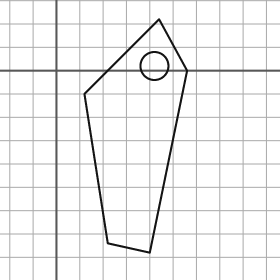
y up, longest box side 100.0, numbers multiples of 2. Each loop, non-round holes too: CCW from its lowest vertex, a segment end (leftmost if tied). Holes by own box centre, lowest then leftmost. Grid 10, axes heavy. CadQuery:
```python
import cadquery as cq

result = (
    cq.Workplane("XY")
    .moveTo(40.0, -78.0)
    .lineTo(56.0, 0.0)
    .lineTo(44.0, 22.0)
    .lineTo(12.0, -10.0)
    .lineTo(22.0, -74.0)
    .close()
    .moveTo(42.0, 2.0)
    .circle(6.0)
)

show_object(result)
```